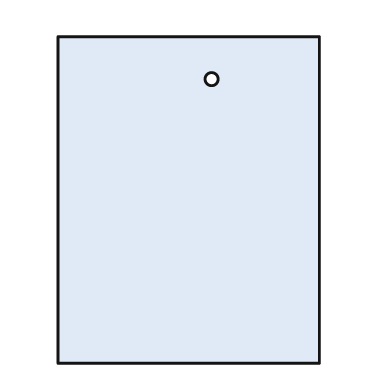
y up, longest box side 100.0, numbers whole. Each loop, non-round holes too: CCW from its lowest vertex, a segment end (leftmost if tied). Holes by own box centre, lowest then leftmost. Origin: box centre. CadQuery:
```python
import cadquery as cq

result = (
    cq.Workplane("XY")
    .moveTo(-40.0, -50.0)
    .lineTo(40.0, -50.0)
    .lineTo(40.0, 50.0)
    .lineTo(-40.0, 50.0)
    .close()
    .moveTo(7.0, 37.0)
    .circle(2.0)
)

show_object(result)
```